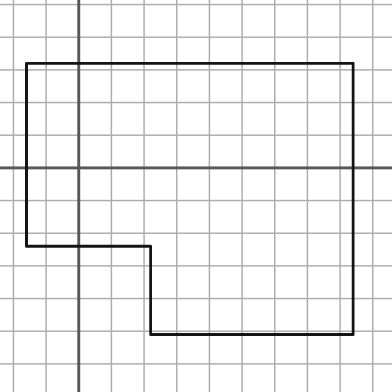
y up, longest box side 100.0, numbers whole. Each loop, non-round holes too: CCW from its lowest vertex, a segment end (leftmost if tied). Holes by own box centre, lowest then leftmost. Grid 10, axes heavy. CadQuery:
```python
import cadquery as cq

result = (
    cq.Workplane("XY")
    .moveTo(22.0, -51.0)
    .lineTo(84.0, -51.0)
    .lineTo(84.0, 32.0)
    .lineTo(-16.0, 32.0)
    .lineTo(-16.0, -24.0)
    .lineTo(22.0, -24.0)
    .close()
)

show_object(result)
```